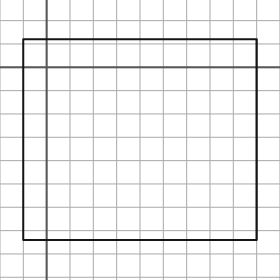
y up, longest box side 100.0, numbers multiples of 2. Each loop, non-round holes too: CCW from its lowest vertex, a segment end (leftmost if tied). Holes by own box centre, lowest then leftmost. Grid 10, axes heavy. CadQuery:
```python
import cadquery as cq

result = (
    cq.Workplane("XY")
    .moveTo(-10.0, -74.0)
    .lineTo(90.0, -74.0)
    .lineTo(90.0, 12.0)
    .lineTo(-10.0, 12.0)
    .close()
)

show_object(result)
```